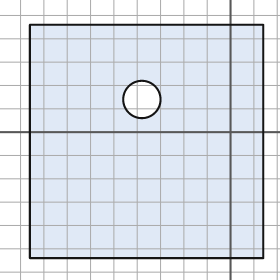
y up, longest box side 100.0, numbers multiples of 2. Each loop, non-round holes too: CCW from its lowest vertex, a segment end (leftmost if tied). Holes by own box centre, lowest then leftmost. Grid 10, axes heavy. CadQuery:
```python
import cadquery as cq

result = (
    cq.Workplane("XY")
    .moveTo(-86.0, -54.0)
    .lineTo(14.0, -54.0)
    .lineTo(14.0, 46.0)
    .lineTo(-86.0, 46.0)
    .close()
    .moveTo(-38.0, 14.0)
    .circle(8.0)
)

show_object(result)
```